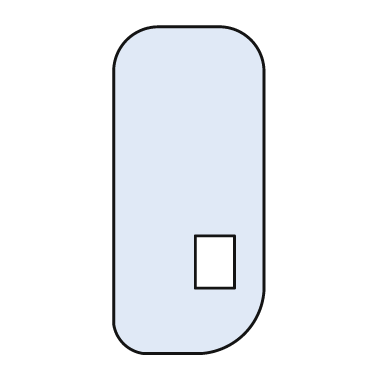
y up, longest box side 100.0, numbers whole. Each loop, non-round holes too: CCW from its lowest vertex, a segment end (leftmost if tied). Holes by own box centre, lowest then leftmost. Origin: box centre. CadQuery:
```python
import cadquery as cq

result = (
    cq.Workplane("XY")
    .moveTo(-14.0, -50.0)
    .lineTo(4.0, -50.0)
    .threePointArc((17.0, -44.0), (23.0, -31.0))
    .lineTo(23.0, 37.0)
    .threePointArc((19.0, 46.0), (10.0, 50.0))
    .lineTo(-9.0, 50.0)
    .threePointArc((-19.0, 46.0), (-23.0, 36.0))
    .lineTo(-23.0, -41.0)
    .threePointArc((-20.0, -47.0), (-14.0, -50.0))
    .close()
    .moveTo(2.0, -30.0)
    .lineTo(14.0, -30.0)
    .lineTo(14.0, -14.0)
    .lineTo(2.0, -14.0)
    .close()
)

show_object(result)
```